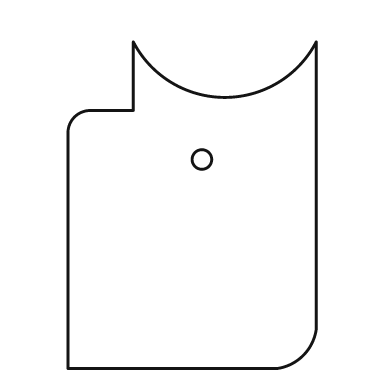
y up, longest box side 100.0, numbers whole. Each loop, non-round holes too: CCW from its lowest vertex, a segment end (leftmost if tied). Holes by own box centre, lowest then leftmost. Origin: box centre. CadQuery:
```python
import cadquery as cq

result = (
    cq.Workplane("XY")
    .moveTo(-38.0, -50.0)
    .lineTo(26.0, -50.0)
    .threePointArc((34.0, -46.0), (38.0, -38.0))
    .lineTo(38.0, 50.0)
    .threePointArc((10.0, 33.0), (-18.0, 50.0))
    .lineTo(-18.0, 29.0)
    .lineTo(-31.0, 29.0)
    .threePointArc((-36.0, 27.0), (-38.0, 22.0))
    .close()
    .moveTo(3.0, 14.0)
    .circle(3.0)
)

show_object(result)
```